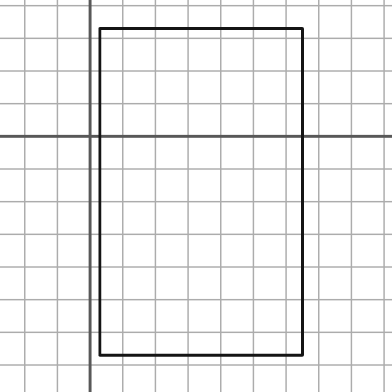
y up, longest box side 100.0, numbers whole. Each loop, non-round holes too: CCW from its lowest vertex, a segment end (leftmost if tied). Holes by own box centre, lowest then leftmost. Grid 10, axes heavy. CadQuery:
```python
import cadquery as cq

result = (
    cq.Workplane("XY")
    .moveTo(3.0, -67.0)
    .lineTo(65.0, -67.0)
    .lineTo(65.0, 33.0)
    .lineTo(3.0, 33.0)
    .close()
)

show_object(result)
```